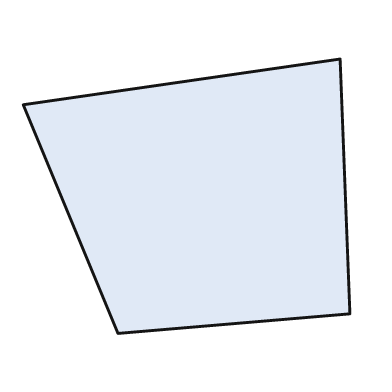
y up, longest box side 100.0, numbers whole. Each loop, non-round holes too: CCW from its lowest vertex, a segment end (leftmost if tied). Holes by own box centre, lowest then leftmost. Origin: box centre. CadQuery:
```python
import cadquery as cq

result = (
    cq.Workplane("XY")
    .moveTo(-21.0, -42.0)
    .lineTo(50.0, -36.0)
    .lineTo(47.0, 42.0)
    .lineTo(-50.0, 28.0)
    .close()
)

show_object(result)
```